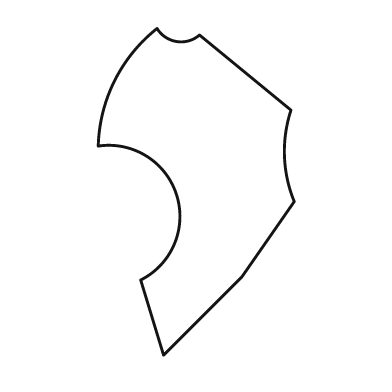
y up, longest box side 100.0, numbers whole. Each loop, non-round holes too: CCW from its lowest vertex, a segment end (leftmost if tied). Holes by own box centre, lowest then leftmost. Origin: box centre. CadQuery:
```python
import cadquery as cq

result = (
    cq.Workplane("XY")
    .moveTo(-10.0, -50.0)
    .lineTo(14.0, -26.0)
    .lineTo(30.0, -3.0)
    .threePointArc((27.0, 11.0), (29.0, 25.0))
    .lineTo(1.0, 48.0)
    .threePointArc((-6.0, 46.0), (-12.0, 50.0))
    .threePointArc((-25.0, 34.0), (-30.0, 14.0))
    .threePointArc((-6.0, -1.0), (-17.0, -27.0))
    .close()
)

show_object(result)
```